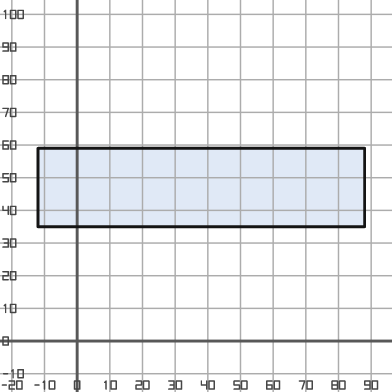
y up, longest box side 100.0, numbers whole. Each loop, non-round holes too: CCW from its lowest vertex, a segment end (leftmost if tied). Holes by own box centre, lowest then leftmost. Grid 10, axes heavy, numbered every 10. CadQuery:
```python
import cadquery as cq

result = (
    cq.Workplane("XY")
    .moveTo(-12.0, 35.0)
    .lineTo(88.0, 35.0)
    .lineTo(88.0, 59.0)
    .lineTo(-12.0, 59.0)
    .close()
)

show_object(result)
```